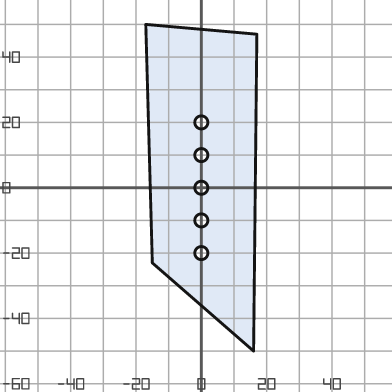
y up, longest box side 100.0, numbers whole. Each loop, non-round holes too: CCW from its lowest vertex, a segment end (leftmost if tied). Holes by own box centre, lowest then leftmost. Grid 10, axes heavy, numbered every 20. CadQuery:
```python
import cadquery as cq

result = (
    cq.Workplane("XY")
    .moveTo(16.0, -50.0)
    .lineTo(17.0, 47.0)
    .lineTo(-17.0, 50.0)
    .lineTo(-15.0, -23.0)
    .close()
    .moveTo(0.0, -20.0)
    .circle(2.0)
    .moveTo(0.0, -10.0)
    .circle(2.0)
    .moveTo(0.0, 0.0)
    .circle(2.0)
    .moveTo(0.0, 10.0)
    .circle(2.0)
    .moveTo(0.0, 20.0)
    .circle(2.0)
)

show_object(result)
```